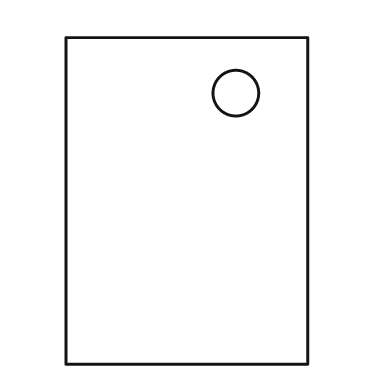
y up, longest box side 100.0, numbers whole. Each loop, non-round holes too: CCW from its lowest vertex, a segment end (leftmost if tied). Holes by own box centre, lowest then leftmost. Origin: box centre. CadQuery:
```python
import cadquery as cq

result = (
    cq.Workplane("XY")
    .moveTo(-37.0, -50.0)
    .lineTo(37.0, -50.0)
    .lineTo(37.0, 50.0)
    .lineTo(-37.0, 50.0)
    .close()
    .moveTo(15.0, 33.0)
    .circle(7.0)
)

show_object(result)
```